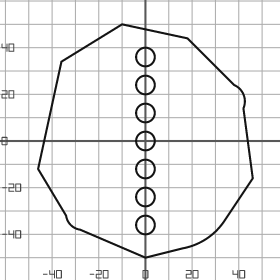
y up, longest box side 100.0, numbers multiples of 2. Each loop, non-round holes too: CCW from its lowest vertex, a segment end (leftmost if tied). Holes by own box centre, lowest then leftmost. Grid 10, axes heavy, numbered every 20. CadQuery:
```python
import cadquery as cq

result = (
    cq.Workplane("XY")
    .moveTo(0.0, -50.0)
    .lineTo(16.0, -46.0)
    .threePointArc((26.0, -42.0), (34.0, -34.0))
    .lineTo(46.0, -16.0)
    .lineTo(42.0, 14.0)
    .threePointArc((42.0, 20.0), (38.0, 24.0))
    .lineTo(18.0, 44.0)
    .lineTo(-10.0, 50.0)
    .lineTo(-36.0, 34.0)
    .lineTo(-46.0, -12.0)
    .lineTo(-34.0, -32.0)
    .threePointArc((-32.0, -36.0), (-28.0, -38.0))
    .close()
    .moveTo(0.0, -36.0)
    .circle(4.0)
    .moveTo(0.0, -24.0)
    .circle(4.0)
    .moveTo(0.0, -12.0)
    .circle(4.0)
    .moveTo(0.0, 0.0)
    .circle(4.0)
    .moveTo(0.0, 12.0)
    .circle(4.0)
    .moveTo(0.0, 24.0)
    .circle(4.0)
    .moveTo(0.0, 36.0)
    .circle(4.0)
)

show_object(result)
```